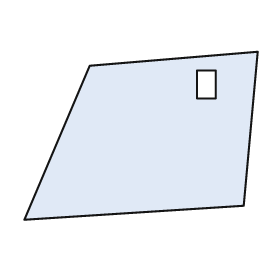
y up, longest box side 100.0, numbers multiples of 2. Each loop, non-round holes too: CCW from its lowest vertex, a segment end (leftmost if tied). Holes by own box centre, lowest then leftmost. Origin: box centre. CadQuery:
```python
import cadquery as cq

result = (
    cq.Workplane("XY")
    .moveTo(-50.0, -36.0)
    .lineTo(44.0, -30.0)
    .lineTo(50.0, 36.0)
    .lineTo(-22.0, 30.0)
    .close()
    .moveTo(24.0, 16.0)
    .lineTo(32.0, 16.0)
    .lineTo(32.0, 28.0)
    .lineTo(24.0, 28.0)
    .close()
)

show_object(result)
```